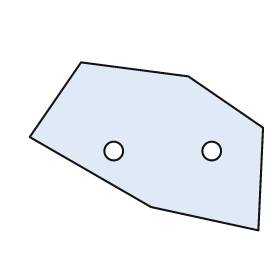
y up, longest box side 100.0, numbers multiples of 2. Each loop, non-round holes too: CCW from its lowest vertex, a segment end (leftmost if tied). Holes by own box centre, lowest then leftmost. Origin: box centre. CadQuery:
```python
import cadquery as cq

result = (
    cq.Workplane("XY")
    .moveTo(48.0, -36.0)
    .lineTo(50.0, 8.0)
    .lineTo(18.0, 30.0)
    .lineTo(-28.0, 36.0)
    .lineTo(-50.0, 4.0)
    .lineTo(2.0, -26.0)
    .close()
    .moveTo(-14.0, -2.0)
    .circle(4.0)
    .moveTo(28.0, -2.0)
    .circle(4.0)
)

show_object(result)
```